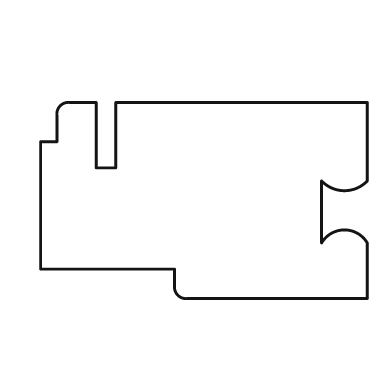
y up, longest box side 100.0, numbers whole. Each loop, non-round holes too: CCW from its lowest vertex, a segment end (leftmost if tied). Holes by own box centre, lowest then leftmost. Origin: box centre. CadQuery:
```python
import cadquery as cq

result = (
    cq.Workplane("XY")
    .moveTo(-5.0, -30.0)
    .lineTo(50.0, -30.0)
    .lineTo(50.0, -13.0)
    .threePointArc((43.0, -9.0), (36.0, -13.0))
    .lineTo(36.0, 6.0)
    .threePointArc((43.0, 3.0), (50.0, 6.0))
    .lineTo(50.0, 30.0)
    .lineTo(-27.0, 30.0)
    .lineTo(-27.0, 10.0)
    .lineTo(-33.0, 10.0)
    .lineTo(-33.0, 30.0)
    .lineTo(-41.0, 30.0)
    .threePointArc((-44.0, 29.0), (-45.0, 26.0))
    .lineTo(-45.0, 18.0)
    .lineTo(-50.0, 18.0)
    .lineTo(-50.0, -21.0)
    .lineTo(-9.0, -21.0)
    .lineTo(-9.0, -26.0)
    .threePointArc((-8.0, -29.0), (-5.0, -30.0))
    .close()
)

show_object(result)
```